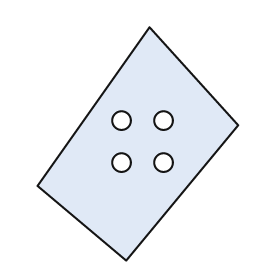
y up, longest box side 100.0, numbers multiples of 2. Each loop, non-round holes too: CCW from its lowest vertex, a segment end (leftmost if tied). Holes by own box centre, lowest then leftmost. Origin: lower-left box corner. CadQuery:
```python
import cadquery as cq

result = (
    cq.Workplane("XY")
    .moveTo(38.0, 0.0)
    .lineTo(86.0, 58.0)
    .lineTo(48.0, 100.0)
    .lineTo(0.0, 32.0)
    .close()
    .moveTo(36.0, 42.0)
    .circle(4.0)
    .moveTo(54.0, 42.0)
    .circle(4.0)
    .moveTo(36.0, 60.0)
    .circle(4.0)
    .moveTo(54.0, 60.0)
    .circle(4.0)
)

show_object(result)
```